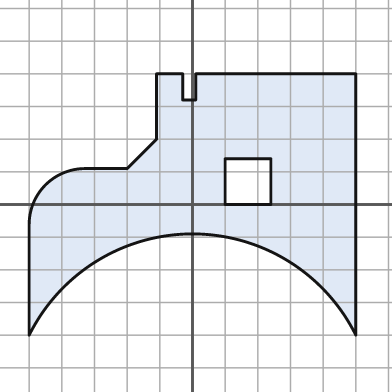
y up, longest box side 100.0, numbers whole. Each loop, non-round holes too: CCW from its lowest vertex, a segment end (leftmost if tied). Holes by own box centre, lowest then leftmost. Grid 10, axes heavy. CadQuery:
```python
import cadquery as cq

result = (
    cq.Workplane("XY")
    .moveTo(-50.0, -40.0)
    .threePointArc((0.0, -9.0), (50.0, -40.0))
    .lineTo(50.0, 40.0)
    .lineTo(1.0, 40.0)
    .lineTo(1.0, 32.0)
    .lineTo(-3.0, 32.0)
    .lineTo(-3.0, 40.0)
    .lineTo(-11.0, 40.0)
    .lineTo(-11.0, 20.0)
    .lineTo(-20.0, 11.0)
    .lineTo(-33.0, 11.0)
    .threePointArc((-45.0, 6.0), (-50.0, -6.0))
    .close()
    .moveTo(10.0, 0.0)
    .lineTo(24.0, 0.0)
    .lineTo(24.0, 14.0)
    .lineTo(10.0, 14.0)
    .close()
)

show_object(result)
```